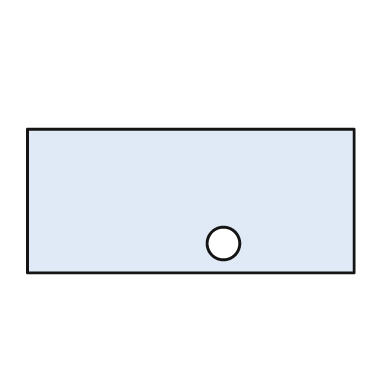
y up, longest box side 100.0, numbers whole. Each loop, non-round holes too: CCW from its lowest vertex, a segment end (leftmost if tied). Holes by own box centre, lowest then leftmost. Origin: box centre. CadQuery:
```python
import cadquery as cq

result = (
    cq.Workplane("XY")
    .moveTo(-50.0, -22.0)
    .lineTo(50.0, -22.0)
    .lineTo(50.0, 22.0)
    .lineTo(-50.0, 22.0)
    .close()
    .moveTo(10.0, -13.0)
    .circle(5.0)
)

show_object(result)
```